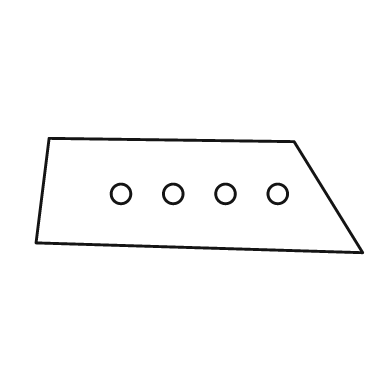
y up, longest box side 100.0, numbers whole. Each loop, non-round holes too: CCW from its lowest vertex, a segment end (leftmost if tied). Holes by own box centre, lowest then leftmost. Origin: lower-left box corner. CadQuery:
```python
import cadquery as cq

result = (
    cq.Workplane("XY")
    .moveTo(100.0, 0.0)
    .lineTo(79.0, 34.0)
    .lineTo(4.0, 35.0)
    .lineTo(0.0, 3.0)
    .close()
    .moveTo(26.0, 18.0)
    .circle(3.0)
    .moveTo(42.0, 18.0)
    .circle(3.0)
    .moveTo(58.0, 18.0)
    .circle(3.0)
    .moveTo(74.0, 18.0)
    .circle(3.0)
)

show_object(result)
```